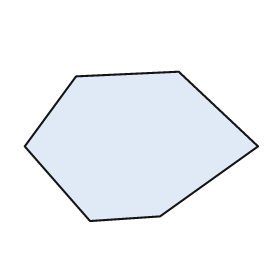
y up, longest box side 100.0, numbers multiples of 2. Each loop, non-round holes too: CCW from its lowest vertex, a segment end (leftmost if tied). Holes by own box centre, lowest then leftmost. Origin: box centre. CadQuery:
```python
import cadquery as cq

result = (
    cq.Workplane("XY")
    .moveTo(-22.0, -32.0)
    .lineTo(8.0, -30.0)
    .lineTo(50.0, 0.0)
    .lineTo(16.0, 32.0)
    .lineTo(-28.0, 30.0)
    .lineTo(-50.0, 0.0)
    .close()
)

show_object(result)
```